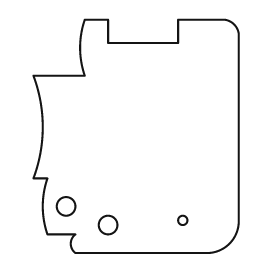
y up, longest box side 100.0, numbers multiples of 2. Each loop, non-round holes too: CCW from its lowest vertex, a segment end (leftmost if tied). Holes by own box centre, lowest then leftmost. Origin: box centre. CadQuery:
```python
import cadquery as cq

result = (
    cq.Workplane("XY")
    .moveTo(-26.0, -50.0)
    .lineTo(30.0, -50.0)
    .threePointArc((40.0, -46.0), (44.0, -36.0))
    .lineTo(44.0, 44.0)
    .threePointArc((42.0, 48.0), (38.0, 50.0))
    .lineTo(18.0, 50.0)
    .lineTo(18.0, 40.0)
    .lineTo(-12.0, 40.0)
    .lineTo(-12.0, 50.0)
    .lineTo(-22.0, 50.0)
    .threePointArc((-24.0, 38.0), (-22.0, 26.0))
    .lineTo(-44.0, 26.0)
    .threePointArc((-40.0, 4.0), (-44.0, -18.0))
    .lineTo(-38.0, -18.0)
    .threePointArc((-40.0, -30.0), (-38.0, -42.0))
    .lineTo(-26.0, -42.0)
    .threePointArc((-28.0, -46.0), (-26.0, -50.0))
    .close()
    .moveTo(-12.0, -38.0)
    .circle(4.0)
    .moveTo(20.0, -36.0)
    .circle(2.0)
    .moveTo(-30.0, -30.0)
    .circle(4.0)
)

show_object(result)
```